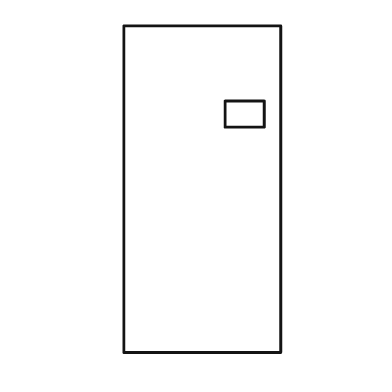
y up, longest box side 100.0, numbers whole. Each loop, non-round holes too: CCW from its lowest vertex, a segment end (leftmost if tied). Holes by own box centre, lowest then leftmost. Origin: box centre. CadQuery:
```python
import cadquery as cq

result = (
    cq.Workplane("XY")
    .moveTo(-24.0, -50.0)
    .lineTo(24.0, -50.0)
    .lineTo(24.0, 50.0)
    .lineTo(-24.0, 50.0)
    .close()
    .moveTo(7.0, 19.0)
    .lineTo(19.0, 19.0)
    .lineTo(19.0, 27.0)
    .lineTo(7.0, 27.0)
    .close()
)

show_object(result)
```